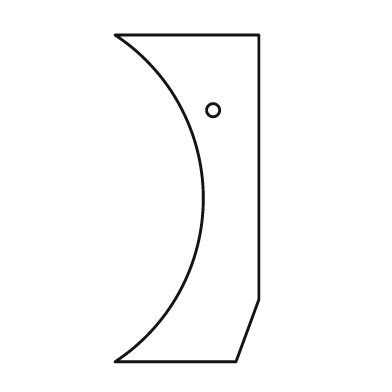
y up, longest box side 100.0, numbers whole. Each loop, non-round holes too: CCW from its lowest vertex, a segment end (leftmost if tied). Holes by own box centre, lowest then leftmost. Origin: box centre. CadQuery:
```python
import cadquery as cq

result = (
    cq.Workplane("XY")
    .moveTo(-22.0, -50.0)
    .lineTo(15.0, -50.0)
    .lineTo(22.0, -31.0)
    .lineTo(22.0, 50.0)
    .lineTo(-22.0, 50.0)
    .threePointArc((5.0, 0.0), (-22.0, -50.0))
    .close()
    .moveTo(8.0, 27.0)
    .circle(2.0)
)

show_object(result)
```